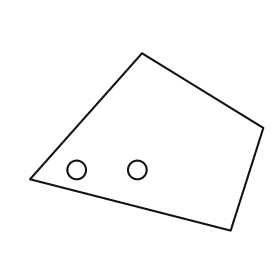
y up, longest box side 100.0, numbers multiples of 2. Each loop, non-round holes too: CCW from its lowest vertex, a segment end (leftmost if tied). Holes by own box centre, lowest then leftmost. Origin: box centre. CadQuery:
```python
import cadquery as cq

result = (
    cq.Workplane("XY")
    .moveTo(36.0, -38.0)
    .lineTo(50.0, 6.0)
    .lineTo(-2.0, 38.0)
    .lineTo(-50.0, -16.0)
    .close()
    .moveTo(-30.0, -12.0)
    .circle(4.0)
    .moveTo(-4.0, -12.0)
    .circle(4.0)
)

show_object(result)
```